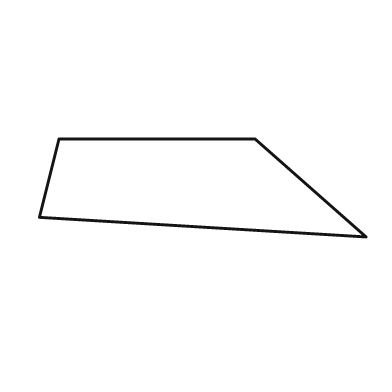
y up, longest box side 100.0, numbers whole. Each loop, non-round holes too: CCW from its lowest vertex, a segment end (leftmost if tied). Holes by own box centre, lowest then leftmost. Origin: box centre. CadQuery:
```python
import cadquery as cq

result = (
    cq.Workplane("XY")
    .moveTo(50.0, -15.0)
    .lineTo(16.0, 15.0)
    .lineTo(-44.0, 15.0)
    .lineTo(-50.0, -9.0)
    .close()
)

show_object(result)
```